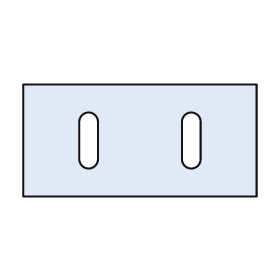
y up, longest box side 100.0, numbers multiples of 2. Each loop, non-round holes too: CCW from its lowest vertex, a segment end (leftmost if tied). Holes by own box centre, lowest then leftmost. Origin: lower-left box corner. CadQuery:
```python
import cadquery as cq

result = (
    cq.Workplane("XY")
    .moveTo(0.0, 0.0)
    .lineTo(100.0, 0.0)
    .lineTo(100.0, 48.0)
    .lineTo(0.0, 48.0)
    .close()
    .moveTo(24.0, 16.0)
    .threePointArc((28.0, 12.0), (32.0, 16.0))
    .lineTo(32.0, 32.0)
    .threePointArc((28.0, 36.0), (24.0, 32.0))
    .close()
    .moveTo(68.0, 16.0)
    .threePointArc((72.0, 12.0), (76.0, 16.0))
    .lineTo(76.0, 32.0)
    .threePointArc((72.0, 36.0), (68.0, 32.0))
    .close()
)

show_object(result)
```